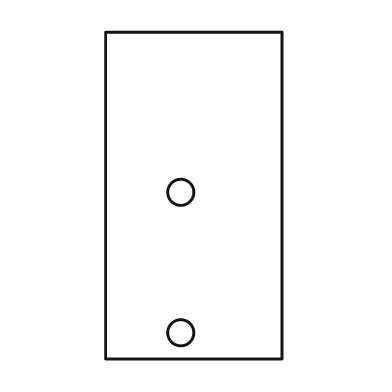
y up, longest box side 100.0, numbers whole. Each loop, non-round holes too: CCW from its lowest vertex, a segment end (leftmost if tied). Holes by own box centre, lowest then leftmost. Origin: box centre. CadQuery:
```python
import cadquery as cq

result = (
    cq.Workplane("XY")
    .moveTo(-27.0, -50.0)
    .lineTo(27.0, -50.0)
    .lineTo(27.0, 50.0)
    .lineTo(-27.0, 50.0)
    .close()
    .moveTo(-4.0, -42.0)
    .circle(4.0)
    .moveTo(-4.0, 1.0)
    .circle(4.0)
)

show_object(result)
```